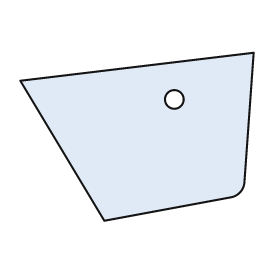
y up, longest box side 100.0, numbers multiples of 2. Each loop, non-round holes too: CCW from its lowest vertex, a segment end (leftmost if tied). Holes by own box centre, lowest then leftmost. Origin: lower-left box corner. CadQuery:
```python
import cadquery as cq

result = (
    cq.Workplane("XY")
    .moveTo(36.0, 0.0)
    .lineTo(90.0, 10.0)
    .threePointArc((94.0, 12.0), (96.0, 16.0))
    .lineTo(100.0, 72.0)
    .lineTo(0.0, 60.0)
    .close()
    .moveTo(66.0, 52.0)
    .circle(4.0)
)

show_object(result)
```